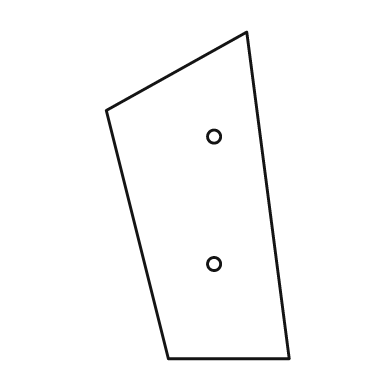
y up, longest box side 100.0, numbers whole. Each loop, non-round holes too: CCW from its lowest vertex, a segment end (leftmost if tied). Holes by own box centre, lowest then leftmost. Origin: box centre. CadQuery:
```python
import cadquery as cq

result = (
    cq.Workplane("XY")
    .moveTo(-9.0, -50.0)
    .lineTo(28.0, -50.0)
    .lineTo(15.0, 50.0)
    .lineTo(-28.0, 26.0)
    .close()
    .moveTo(5.0, -21.0)
    .circle(2.0)
    .moveTo(5.0, 18.0)
    .circle(2.0)
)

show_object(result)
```